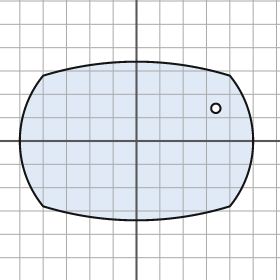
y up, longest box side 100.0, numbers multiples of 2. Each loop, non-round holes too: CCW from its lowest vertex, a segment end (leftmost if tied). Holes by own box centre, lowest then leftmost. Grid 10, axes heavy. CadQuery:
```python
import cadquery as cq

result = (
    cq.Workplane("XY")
    .moveTo(-40.0, -28.0)
    .threePointArc((0.0, -34.0), (40.0, -28.0))
    .threePointArc((50.0, 0.0), (40.0, 28.0))
    .threePointArc((0.0, 34.0), (-40.0, 28.0))
    .threePointArc((-50.0, 0.0), (-40.0, -28.0))
    .close()
    .moveTo(34.0, 14.0)
    .circle(2.0)
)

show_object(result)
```